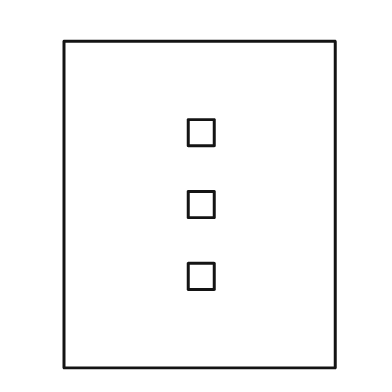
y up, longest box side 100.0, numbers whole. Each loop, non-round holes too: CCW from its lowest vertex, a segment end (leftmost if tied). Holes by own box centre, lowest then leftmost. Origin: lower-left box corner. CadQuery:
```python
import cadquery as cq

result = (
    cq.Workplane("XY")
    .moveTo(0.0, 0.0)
    .lineTo(83.0, 0.0)
    .lineTo(83.0, 100.0)
    .lineTo(0.0, 100.0)
    .close()
    .moveTo(38.0, 24.0)
    .lineTo(46.0, 24.0)
    .lineTo(46.0, 32.0)
    .lineTo(38.0, 32.0)
    .close()
    .moveTo(38.0, 46.0)
    .lineTo(46.0, 46.0)
    .lineTo(46.0, 54.0)
    .lineTo(38.0, 54.0)
    .close()
    .moveTo(38.0, 68.0)
    .lineTo(46.0, 68.0)
    .lineTo(46.0, 76.0)
    .lineTo(38.0, 76.0)
    .close()
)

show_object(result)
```